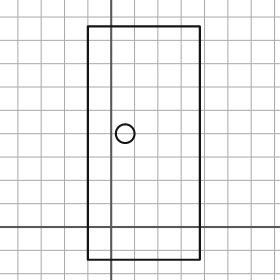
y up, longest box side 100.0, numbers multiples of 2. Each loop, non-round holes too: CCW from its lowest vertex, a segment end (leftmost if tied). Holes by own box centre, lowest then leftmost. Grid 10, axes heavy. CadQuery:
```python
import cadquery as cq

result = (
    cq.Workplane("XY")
    .moveTo(-10.0, -14.0)
    .lineTo(38.0, -14.0)
    .lineTo(38.0, 86.0)
    .lineTo(-10.0, 86.0)
    .close()
    .moveTo(6.0, 40.0)
    .circle(4.0)
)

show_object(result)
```